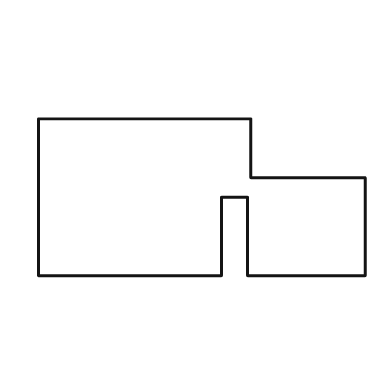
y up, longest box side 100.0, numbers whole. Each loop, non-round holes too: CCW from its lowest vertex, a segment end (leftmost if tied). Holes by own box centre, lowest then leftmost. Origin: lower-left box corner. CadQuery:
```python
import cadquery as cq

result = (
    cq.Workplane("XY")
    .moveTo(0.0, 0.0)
    .lineTo(56.0, 0.0)
    .lineTo(56.0, 24.0)
    .lineTo(64.0, 24.0)
    .lineTo(64.0, 0.0)
    .lineTo(100.0, 0.0)
    .lineTo(100.0, 30.0)
    .lineTo(65.0, 30.0)
    .lineTo(65.0, 48.0)
    .lineTo(0.0, 48.0)
    .close()
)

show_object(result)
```